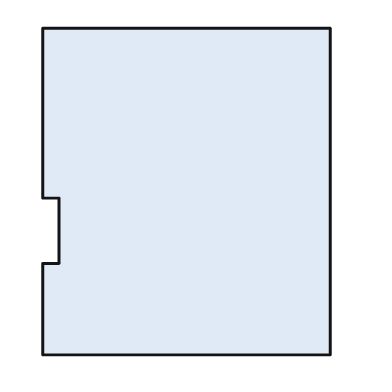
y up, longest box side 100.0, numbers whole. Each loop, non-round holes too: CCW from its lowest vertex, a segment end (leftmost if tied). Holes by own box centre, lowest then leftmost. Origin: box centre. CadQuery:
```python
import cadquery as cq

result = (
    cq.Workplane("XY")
    .moveTo(-44.0, -50.0)
    .lineTo(44.0, -50.0)
    .lineTo(44.0, 50.0)
    .lineTo(-44.0, 50.0)
    .lineTo(-44.0, -2.0)
    .lineTo(-39.0, -2.0)
    .lineTo(-39.0, -22.0)
    .lineTo(-44.0, -22.0)
    .close()
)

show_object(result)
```